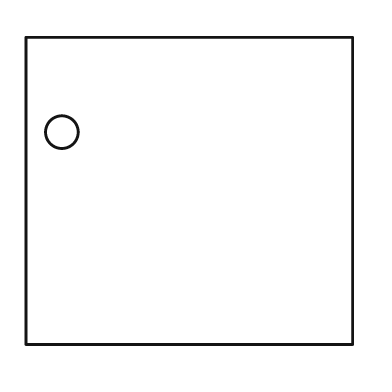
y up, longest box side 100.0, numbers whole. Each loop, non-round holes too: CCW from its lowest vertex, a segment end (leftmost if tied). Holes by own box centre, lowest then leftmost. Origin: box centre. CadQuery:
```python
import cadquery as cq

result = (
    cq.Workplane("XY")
    .moveTo(-50.0, -47.0)
    .lineTo(50.0, -47.0)
    .lineTo(50.0, 47.0)
    .lineTo(-50.0, 47.0)
    .close()
    .moveTo(-39.0, 18.0)
    .circle(5.0)
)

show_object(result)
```